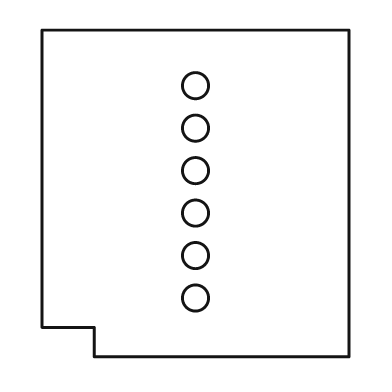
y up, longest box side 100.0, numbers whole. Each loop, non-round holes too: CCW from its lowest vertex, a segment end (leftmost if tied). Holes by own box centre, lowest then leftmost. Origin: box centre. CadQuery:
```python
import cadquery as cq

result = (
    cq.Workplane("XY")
    .moveTo(-31.0, -50.0)
    .lineTo(47.0, -50.0)
    .lineTo(47.0, 50.0)
    .lineTo(-47.0, 50.0)
    .lineTo(-47.0, -41.0)
    .lineTo(-31.0, -41.0)
    .close()
    .moveTo(0.0, -32.0)
    .circle(4.0)
    .moveTo(0.0, -19.0)
    .circle(4.0)
    .moveTo(0.0, -6.0)
    .circle(4.0)
    .moveTo(0.0, 7.0)
    .circle(4.0)
    .moveTo(0.0, 20.0)
    .circle(4.0)
    .moveTo(0.0, 33.0)
    .circle(4.0)
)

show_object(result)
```